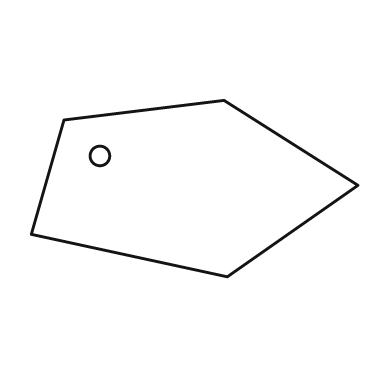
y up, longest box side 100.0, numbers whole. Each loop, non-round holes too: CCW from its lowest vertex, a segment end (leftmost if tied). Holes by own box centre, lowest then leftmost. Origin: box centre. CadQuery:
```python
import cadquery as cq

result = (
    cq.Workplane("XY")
    .moveTo(10.0, -27.0)
    .lineTo(50.0, 1.0)
    .lineTo(9.0, 27.0)
    .lineTo(-40.0, 21.0)
    .lineTo(-50.0, -14.0)
    .close()
    .moveTo(-29.0, 10.0)
    .circle(3.0)
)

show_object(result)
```